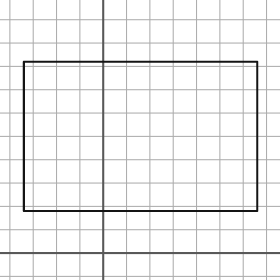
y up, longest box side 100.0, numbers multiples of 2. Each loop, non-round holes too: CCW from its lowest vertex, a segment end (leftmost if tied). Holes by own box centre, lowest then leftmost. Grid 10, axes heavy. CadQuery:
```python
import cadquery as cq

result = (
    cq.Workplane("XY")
    .moveTo(-34.0, 18.0)
    .lineTo(66.0, 18.0)
    .lineTo(66.0, 82.0)
    .lineTo(-34.0, 82.0)
    .close()
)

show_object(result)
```